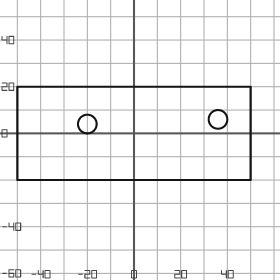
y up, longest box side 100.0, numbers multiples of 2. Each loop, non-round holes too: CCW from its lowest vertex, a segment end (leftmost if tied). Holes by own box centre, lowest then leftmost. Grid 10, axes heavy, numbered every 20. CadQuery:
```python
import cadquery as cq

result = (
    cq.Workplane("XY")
    .moveTo(-50.0, -20.0)
    .lineTo(50.0, -20.0)
    .lineTo(50.0, 20.0)
    .lineTo(-50.0, 20.0)
    .close()
    .moveTo(-20.0, 4.0)
    .circle(4.0)
    .moveTo(36.0, 6.0)
    .circle(4.0)
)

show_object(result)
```